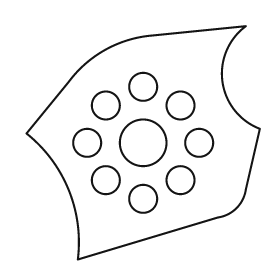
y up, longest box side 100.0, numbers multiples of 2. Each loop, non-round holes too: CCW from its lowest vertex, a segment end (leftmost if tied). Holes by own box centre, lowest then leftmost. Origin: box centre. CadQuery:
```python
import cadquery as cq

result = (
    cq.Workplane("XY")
    .moveTo(-28.0, -50.0)
    .lineTo(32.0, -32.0)
    .threePointArc((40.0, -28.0), (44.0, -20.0))
    .lineTo(50.0, 6.0)
    .threePointArc((34.0, 26.0), (44.0, 50.0))
    .lineTo(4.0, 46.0)
    .threePointArc((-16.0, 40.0), (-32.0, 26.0))
    .lineTo(-50.0, 4.0)
    .threePointArc((-32.0, -20.0), (-28.0, -50.0))
    .close()
    .moveTo(0.0, -24.0)
    .circle(6.0)
    .moveTo(-16.0, -16.0)
    .circle(6.0)
    .moveTo(16.0, -16.0)
    .circle(6.0)
    .moveTo(-24.0, 0.0)
    .circle(6.0)
    .moveTo(0.0, 0.0)
    .circle(10.0)
    .moveTo(24.0, 0.0)
    .circle(6.0)
    .moveTo(-16.0, 16.0)
    .circle(6.0)
    .moveTo(16.0, 16.0)
    .circle(6.0)
    .moveTo(0.0, 24.0)
    .circle(6.0)
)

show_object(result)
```